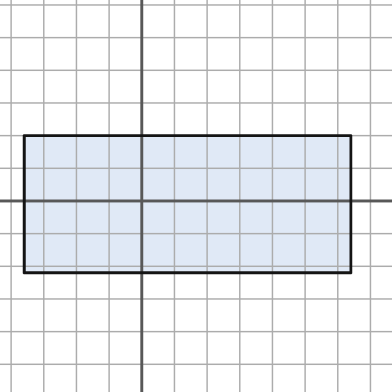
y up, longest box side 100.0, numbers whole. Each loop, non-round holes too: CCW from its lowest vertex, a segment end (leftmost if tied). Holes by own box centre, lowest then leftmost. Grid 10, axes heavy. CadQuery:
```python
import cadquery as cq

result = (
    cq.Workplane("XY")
    .moveTo(-36.0, -22.0)
    .lineTo(64.0, -22.0)
    .lineTo(64.0, 20.0)
    .lineTo(-36.0, 20.0)
    .close()
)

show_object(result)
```